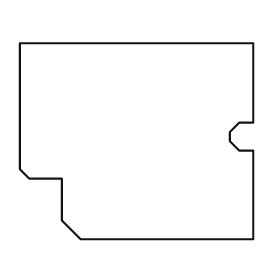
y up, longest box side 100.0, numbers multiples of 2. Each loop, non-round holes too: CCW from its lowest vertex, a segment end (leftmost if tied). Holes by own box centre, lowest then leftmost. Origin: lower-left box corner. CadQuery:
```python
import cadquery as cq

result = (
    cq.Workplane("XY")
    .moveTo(26.0, 0.0)
    .lineTo(100.0, 0.0)
    .lineTo(100.0, 38.0)
    .lineTo(94.0, 38.0)
    .lineTo(90.0, 42.0)
    .lineTo(90.0, 46.0)
    .lineTo(94.0, 50.0)
    .lineTo(100.0, 50.0)
    .lineTo(100.0, 84.0)
    .lineTo(0.0, 84.0)
    .lineTo(0.0, 30.0)
    .lineTo(4.0, 26.0)
    .lineTo(18.0, 26.0)
    .lineTo(18.0, 8.0)
    .close()
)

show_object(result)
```